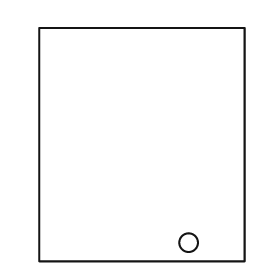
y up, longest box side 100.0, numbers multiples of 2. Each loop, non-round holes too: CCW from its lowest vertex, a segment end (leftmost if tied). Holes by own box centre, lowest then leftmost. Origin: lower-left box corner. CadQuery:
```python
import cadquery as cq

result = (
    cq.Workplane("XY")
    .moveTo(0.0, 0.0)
    .lineTo(88.0, 0.0)
    .lineTo(88.0, 100.0)
    .lineTo(0.0, 100.0)
    .close()
    .moveTo(64.0, 8.0)
    .circle(4.0)
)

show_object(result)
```